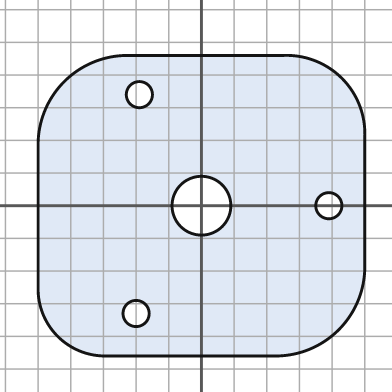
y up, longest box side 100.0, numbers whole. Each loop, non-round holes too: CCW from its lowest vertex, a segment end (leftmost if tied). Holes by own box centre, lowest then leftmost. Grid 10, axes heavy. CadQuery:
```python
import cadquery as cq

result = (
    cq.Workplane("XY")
    .moveTo(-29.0, -46.0)
    .lineTo(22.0, -46.0)
    .threePointArc((42.0, -38.0), (50.0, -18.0))
    .lineTo(50.0, 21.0)
    .threePointArc((43.0, 39.0), (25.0, 46.0))
    .lineTo(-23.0, 46.0)
    .threePointArc((-42.0, 38.0), (-50.0, 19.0))
    .lineTo(-50.0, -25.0)
    .threePointArc((-44.0, -40.0), (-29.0, -46.0))
    .close()
    .moveTo(-20.0, -33.0)
    .circle(4.0)
    .moveTo(0.0, 0.0)
    .circle(9.0)
    .moveTo(39.0, 0.0)
    .circle(4.0)
    .moveTo(-19.0, 34.0)
    .circle(4.0)
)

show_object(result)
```